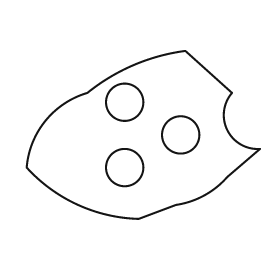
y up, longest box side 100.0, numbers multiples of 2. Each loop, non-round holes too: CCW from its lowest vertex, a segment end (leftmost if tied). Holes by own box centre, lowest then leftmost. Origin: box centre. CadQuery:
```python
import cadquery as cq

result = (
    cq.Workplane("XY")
    .moveTo(-2.0, -36.0)
    .lineTo(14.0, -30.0)
    .threePointArc((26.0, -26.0), (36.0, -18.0))
    .lineTo(50.0, -6.0)
    .threePointArc((36.0, 2.0), (38.0, 18.0))
    .lineTo(18.0, 36.0)
    .threePointArc((-4.0, 30.0), (-24.0, 18.0))
    .threePointArc((-42.0, 6.0), (-50.0, -14.0))
    .threePointArc((-28.0, -30.0), (-2.0, -36.0))
    .close()
    .moveTo(-8.0, -14.0)
    .circle(8.0)
    .moveTo(16.0, 0.0)
    .circle(8.0)
    .moveTo(-8.0, 14.0)
    .circle(8.0)
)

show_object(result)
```